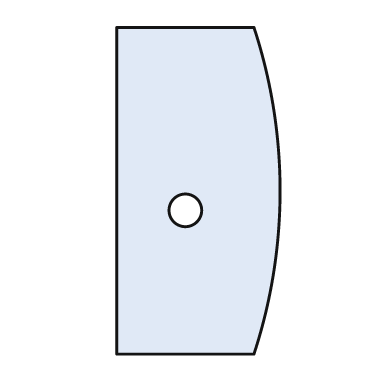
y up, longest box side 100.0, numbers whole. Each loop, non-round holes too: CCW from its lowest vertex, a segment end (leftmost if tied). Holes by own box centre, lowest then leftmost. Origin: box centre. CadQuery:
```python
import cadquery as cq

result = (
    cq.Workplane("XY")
    .moveTo(-25.0, -50.0)
    .lineTo(17.0, -50.0)
    .threePointArc((25.0, 0.0), (17.0, 50.0))
    .lineTo(-25.0, 50.0)
    .close()
    .moveTo(-4.0, -6.0)
    .circle(5.0)
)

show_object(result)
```